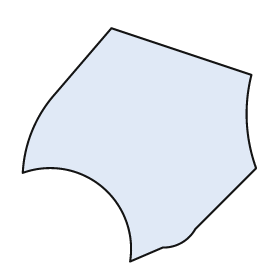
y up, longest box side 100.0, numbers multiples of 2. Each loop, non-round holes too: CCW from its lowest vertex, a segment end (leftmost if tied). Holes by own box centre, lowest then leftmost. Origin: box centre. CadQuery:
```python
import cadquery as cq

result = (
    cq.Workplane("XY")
    .moveTo(-4.0, -50.0)
    .lineTo(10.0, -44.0)
    .threePointArc((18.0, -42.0), (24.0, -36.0))
    .lineTo(50.0, -10.0)
    .threePointArc((46.0, 10.0), (48.0, 30.0))
    .lineTo(-12.0, 50.0)
    .lineTo(-36.0, 22.0)
    .threePointArc((-46.0, 6.0), (-50.0, -12.0))
    .threePointArc((-16.0, -18.0), (-4.0, -50.0))
    .close()
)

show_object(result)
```